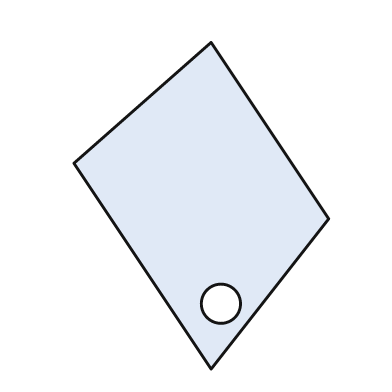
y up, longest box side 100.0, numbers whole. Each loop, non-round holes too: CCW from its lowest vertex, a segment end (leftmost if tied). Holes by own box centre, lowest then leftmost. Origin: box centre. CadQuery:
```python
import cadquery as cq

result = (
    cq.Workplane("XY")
    .moveTo(3.0, -50.0)
    .lineTo(39.0, -4.0)
    .lineTo(3.0, 50.0)
    .lineTo(-39.0, 13.0)
    .close()
    .moveTo(6.0, -30.0)
    .circle(6.0)
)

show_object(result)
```